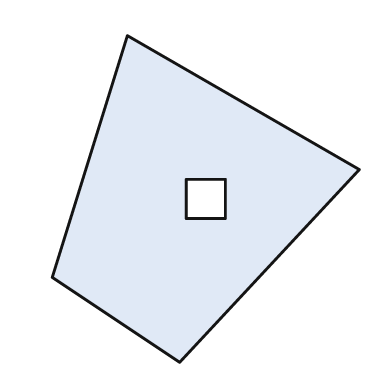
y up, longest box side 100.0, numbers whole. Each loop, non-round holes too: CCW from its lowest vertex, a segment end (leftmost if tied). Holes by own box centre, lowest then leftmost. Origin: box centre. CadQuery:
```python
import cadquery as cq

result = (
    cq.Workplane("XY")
    .moveTo(-8.0, -50.0)
    .lineTo(47.0, 9.0)
    .lineTo(-24.0, 50.0)
    .lineTo(-47.0, -24.0)
    .close()
    .moveTo(-6.0, -6.0)
    .lineTo(6.0, -6.0)
    .lineTo(6.0, 6.0)
    .lineTo(-6.0, 6.0)
    .close()
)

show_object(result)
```